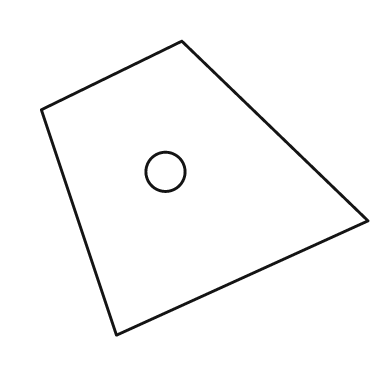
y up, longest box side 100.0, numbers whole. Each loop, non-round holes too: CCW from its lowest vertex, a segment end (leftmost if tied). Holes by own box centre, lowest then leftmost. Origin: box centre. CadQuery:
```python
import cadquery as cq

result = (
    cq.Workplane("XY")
    .moveTo(-27.0, -45.0)
    .lineTo(50.0, -10.0)
    .lineTo(-7.0, 45.0)
    .lineTo(-50.0, 24.0)
    .close()
    .moveTo(-12.0, 5.0)
    .circle(6.0)
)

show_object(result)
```